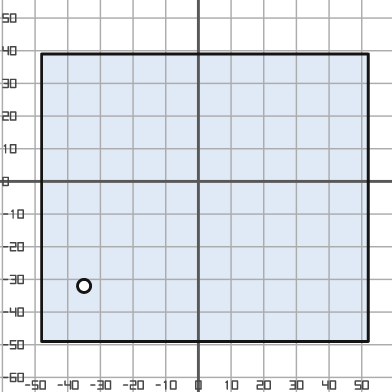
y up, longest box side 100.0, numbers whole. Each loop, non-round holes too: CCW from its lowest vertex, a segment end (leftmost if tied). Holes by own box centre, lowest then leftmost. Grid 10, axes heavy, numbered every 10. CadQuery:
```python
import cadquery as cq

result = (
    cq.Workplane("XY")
    .moveTo(-48.0, -49.0)
    .lineTo(52.0, -49.0)
    .lineTo(52.0, 39.0)
    .lineTo(-48.0, 39.0)
    .close()
    .moveTo(-35.0, -32.0)
    .circle(2.0)
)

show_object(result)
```